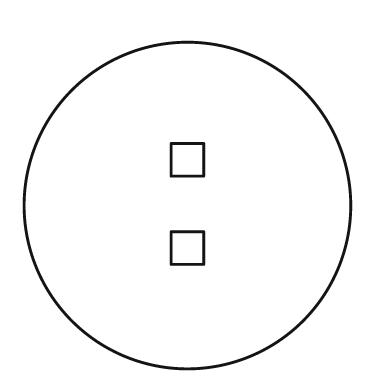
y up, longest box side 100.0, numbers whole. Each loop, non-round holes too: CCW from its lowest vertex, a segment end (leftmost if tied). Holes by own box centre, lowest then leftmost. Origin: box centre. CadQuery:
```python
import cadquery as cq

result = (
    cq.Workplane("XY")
    .moveTo(0.0, 0.0)
    .circle(50.0)
    .moveTo(-5.0, -18.0)
    .lineTo(5.0, -18.0)
    .lineTo(5.0, -8.0)
    .lineTo(-5.0, -8.0)
    .close()
    .moveTo(-5.0, 9.0)
    .lineTo(5.0, 9.0)
    .lineTo(5.0, 19.0)
    .lineTo(-5.0, 19.0)
    .close()
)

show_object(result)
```